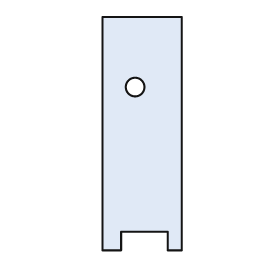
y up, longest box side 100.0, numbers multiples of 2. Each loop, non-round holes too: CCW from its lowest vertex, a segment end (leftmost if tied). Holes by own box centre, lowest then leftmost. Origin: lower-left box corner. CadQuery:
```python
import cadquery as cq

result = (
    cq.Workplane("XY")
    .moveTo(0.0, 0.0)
    .lineTo(8.0, 0.0)
    .lineTo(8.0, 8.0)
    .lineTo(28.0, 8.0)
    .lineTo(28.0, 0.0)
    .lineTo(34.0, 0.0)
    .lineTo(34.0, 100.0)
    .lineTo(0.0, 100.0)
    .close()
    .moveTo(14.0, 70.0)
    .circle(4.0)
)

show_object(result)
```